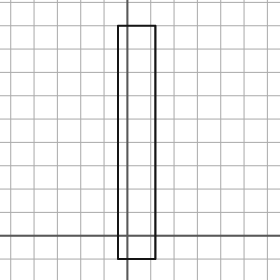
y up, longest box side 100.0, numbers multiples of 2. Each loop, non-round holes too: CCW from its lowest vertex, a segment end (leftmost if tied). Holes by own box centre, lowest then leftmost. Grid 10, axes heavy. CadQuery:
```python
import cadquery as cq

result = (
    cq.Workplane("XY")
    .moveTo(-4.0, -10.0)
    .lineTo(12.0, -10.0)
    .lineTo(12.0, 90.0)
    .lineTo(-4.0, 90.0)
    .close()
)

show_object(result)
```